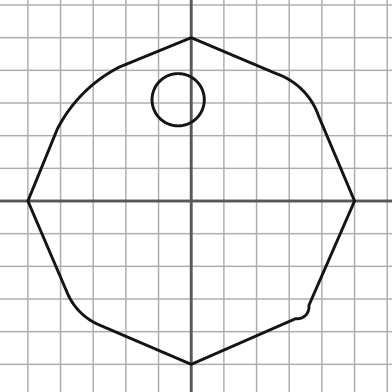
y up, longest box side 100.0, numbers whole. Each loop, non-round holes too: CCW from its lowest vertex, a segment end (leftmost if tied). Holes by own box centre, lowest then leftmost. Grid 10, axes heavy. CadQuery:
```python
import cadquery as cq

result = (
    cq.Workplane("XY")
    .moveTo(0.0, -50.0)
    .lineTo(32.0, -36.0)
    .threePointArc((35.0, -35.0), (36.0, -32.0))
    .lineTo(50.0, 0.0)
    .lineTo(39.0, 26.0)
    .threePointArc((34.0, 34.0), (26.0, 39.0))
    .lineTo(0.0, 50.0)
    .lineTo(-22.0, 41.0)
    .threePointArc((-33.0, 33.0), (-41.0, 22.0))
    .lineTo(-50.0, 0.0)
    .lineTo(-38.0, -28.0)
    .threePointArc((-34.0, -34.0), (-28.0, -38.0))
    .close()
    .moveTo(-4.0, 31.0)
    .circle(8.0)
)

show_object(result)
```